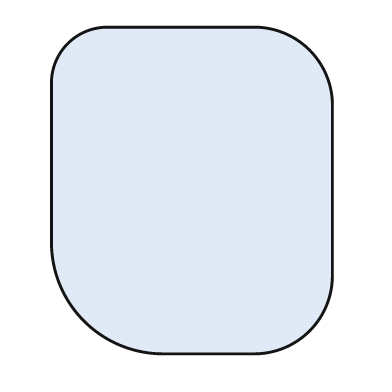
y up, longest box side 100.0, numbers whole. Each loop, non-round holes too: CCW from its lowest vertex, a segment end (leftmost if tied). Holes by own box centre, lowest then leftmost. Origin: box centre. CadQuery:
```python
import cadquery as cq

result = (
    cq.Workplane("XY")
    .moveTo(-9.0, -50.0)
    .lineTo(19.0, -50.0)
    .threePointArc((36.0, -43.0), (43.0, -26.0))
    .lineTo(43.0, 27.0)
    .threePointArc((36.0, 43.0), (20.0, 50.0))
    .lineTo(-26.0, 50.0)
    .threePointArc((-38.0, 45.0), (-43.0, 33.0))
    .lineTo(-43.0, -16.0)
    .threePointArc((-33.0, -40.0), (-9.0, -50.0))
    .close()
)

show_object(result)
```